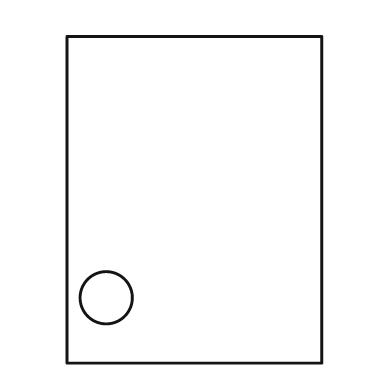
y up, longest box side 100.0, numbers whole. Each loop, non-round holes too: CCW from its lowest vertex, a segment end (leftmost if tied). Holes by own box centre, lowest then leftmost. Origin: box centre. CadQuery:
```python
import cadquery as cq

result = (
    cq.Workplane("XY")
    .moveTo(-39.0, -50.0)
    .lineTo(39.0, -50.0)
    .lineTo(39.0, 50.0)
    .lineTo(-39.0, 50.0)
    .close()
    .moveTo(-27.0, -30.0)
    .circle(8.0)
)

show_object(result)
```